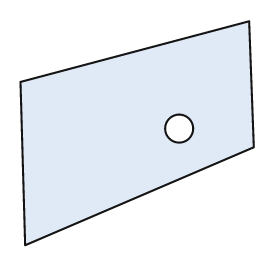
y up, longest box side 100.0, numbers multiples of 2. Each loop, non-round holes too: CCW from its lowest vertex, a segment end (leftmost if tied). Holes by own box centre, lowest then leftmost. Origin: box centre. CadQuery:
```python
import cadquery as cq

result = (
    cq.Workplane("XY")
    .moveTo(-48.0, -48.0)
    .lineTo(50.0, -6.0)
    .lineTo(48.0, 48.0)
    .lineTo(-50.0, 22.0)
    .close()
    .moveTo(18.0, 2.0)
    .circle(6.0)
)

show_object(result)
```